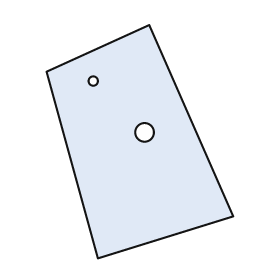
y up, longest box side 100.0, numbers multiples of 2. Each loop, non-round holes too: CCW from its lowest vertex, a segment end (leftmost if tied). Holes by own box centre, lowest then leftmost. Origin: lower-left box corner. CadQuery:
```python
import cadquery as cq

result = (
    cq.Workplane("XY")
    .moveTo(22.0, 0.0)
    .lineTo(80.0, 18.0)
    .lineTo(44.0, 100.0)
    .lineTo(0.0, 80.0)
    .close()
    .moveTo(42.0, 54.0)
    .circle(4.0)
    .moveTo(20.0, 76.0)
    .circle(2.0)
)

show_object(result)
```